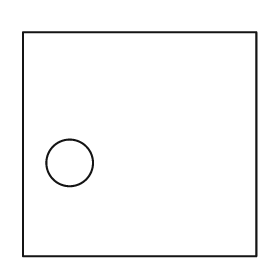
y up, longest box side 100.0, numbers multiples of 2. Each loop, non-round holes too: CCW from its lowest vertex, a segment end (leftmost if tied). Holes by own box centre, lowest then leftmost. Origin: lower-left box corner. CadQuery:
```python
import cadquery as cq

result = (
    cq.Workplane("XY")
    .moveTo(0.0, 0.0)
    .lineTo(100.0, 0.0)
    .lineTo(100.0, 96.0)
    .lineTo(0.0, 96.0)
    .close()
    .moveTo(20.0, 40.0)
    .circle(10.0)
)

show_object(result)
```